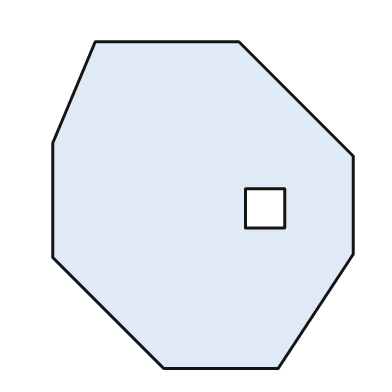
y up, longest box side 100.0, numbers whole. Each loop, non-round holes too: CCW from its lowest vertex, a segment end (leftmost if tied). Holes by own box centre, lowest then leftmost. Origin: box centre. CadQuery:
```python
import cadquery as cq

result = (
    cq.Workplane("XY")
    .moveTo(-12.0, -50.0)
    .lineTo(23.0, -50.0)
    .lineTo(46.0, -15.0)
    .lineTo(46.0, 15.0)
    .lineTo(11.0, 50.0)
    .lineTo(-33.0, 50.0)
    .lineTo(-46.0, 19.0)
    .lineTo(-46.0, -16.0)
    .close()
    .moveTo(13.0, -7.0)
    .lineTo(25.0, -7.0)
    .lineTo(25.0, 5.0)
    .lineTo(13.0, 5.0)
    .close()
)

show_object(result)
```